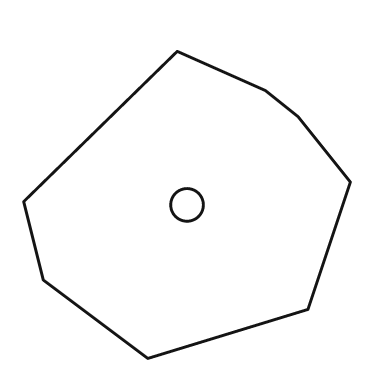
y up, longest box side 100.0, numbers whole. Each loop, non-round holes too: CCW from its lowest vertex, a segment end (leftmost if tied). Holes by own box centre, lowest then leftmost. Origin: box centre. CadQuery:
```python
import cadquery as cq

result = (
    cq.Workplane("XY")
    .moveTo(-12.0, -47.0)
    .lineTo(37.0, -32.0)
    .lineTo(50.0, 7.0)
    .lineTo(34.0, 27.0)
    .lineTo(24.0, 35.0)
    .lineTo(-3.0, 47.0)
    .lineTo(-50.0, 1.0)
    .lineTo(-44.0, -23.0)
    .close()
    .moveTo(0.0, 0.0)
    .circle(5.0)
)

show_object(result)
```